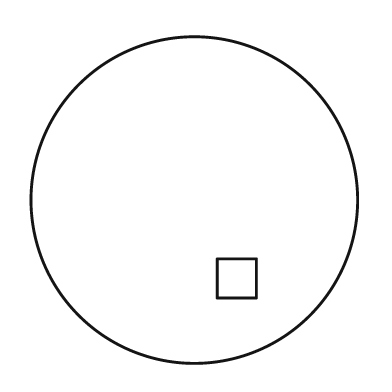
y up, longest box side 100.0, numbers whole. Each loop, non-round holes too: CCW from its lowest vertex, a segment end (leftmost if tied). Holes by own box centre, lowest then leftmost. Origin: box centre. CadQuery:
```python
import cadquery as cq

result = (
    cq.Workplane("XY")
    .moveTo(0.0, 0.0)
    .circle(50.0)
    .moveTo(7.0, -30.0)
    .lineTo(19.0, -30.0)
    .lineTo(19.0, -18.0)
    .lineTo(7.0, -18.0)
    .close()
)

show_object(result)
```